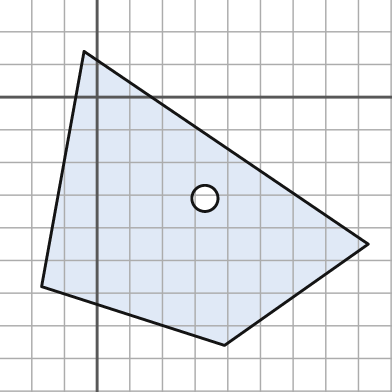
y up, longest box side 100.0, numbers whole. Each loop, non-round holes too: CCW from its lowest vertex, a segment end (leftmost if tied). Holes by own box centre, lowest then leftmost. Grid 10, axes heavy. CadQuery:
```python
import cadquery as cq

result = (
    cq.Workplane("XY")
    .moveTo(39.0, -76.0)
    .lineTo(83.0, -45.0)
    .lineTo(-4.0, 14.0)
    .lineTo(-17.0, -58.0)
    .close()
    .moveTo(33.0, -31.0)
    .circle(4.0)
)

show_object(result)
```